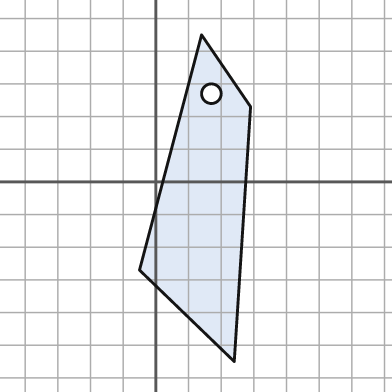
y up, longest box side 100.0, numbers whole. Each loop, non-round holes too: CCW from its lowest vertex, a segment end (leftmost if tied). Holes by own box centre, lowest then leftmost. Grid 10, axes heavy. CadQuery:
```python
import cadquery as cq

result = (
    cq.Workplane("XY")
    .moveTo(24.0, -55.0)
    .lineTo(29.0, 23.0)
    .lineTo(14.0, 45.0)
    .lineTo(-5.0, -27.0)
    .close()
    .moveTo(17.0, 27.0)
    .circle(3.0)
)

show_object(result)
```